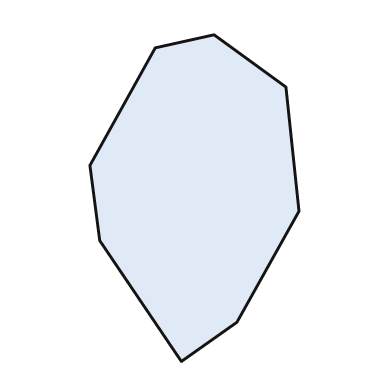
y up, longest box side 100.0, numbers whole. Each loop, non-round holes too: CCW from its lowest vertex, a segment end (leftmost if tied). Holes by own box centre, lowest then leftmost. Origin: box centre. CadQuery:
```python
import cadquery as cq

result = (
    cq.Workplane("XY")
    .moveTo(-4.0, -50.0)
    .lineTo(13.0, -38.0)
    .lineTo(32.0, -4.0)
    .lineTo(28.0, 34.0)
    .lineTo(6.0, 50.0)
    .lineTo(-12.0, 46.0)
    .lineTo(-32.0, 10.0)
    .lineTo(-29.0, -13.0)
    .close()
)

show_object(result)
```